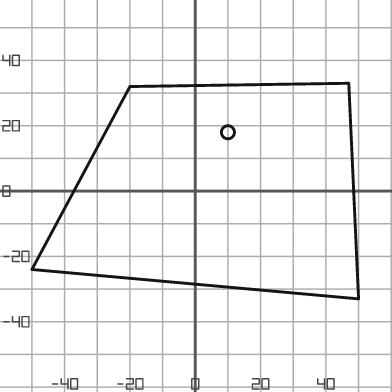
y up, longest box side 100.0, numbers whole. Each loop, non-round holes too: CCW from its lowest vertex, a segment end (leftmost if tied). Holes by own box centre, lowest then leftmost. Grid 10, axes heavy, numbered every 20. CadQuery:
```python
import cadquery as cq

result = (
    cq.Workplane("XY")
    .moveTo(50.0, -33.0)
    .lineTo(47.0, 33.0)
    .lineTo(-20.0, 32.0)
    .lineTo(-50.0, -24.0)
    .close()
    .moveTo(10.0, 18.0)
    .circle(2.0)
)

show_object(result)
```